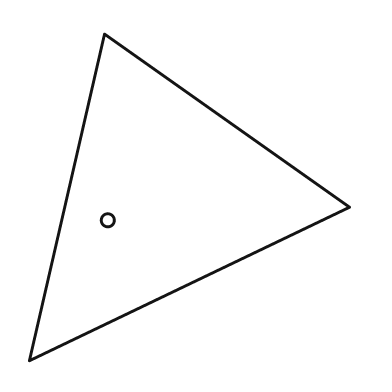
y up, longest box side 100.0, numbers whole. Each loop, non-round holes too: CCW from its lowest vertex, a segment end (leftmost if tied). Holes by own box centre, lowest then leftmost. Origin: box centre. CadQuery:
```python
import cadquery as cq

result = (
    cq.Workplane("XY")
    .moveTo(-49.0, -50.0)
    .lineTo(49.0, -3.0)
    .lineTo(-26.0, 50.0)
    .close()
    .moveTo(-25.0, -7.0)
    .circle(2.0)
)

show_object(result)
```